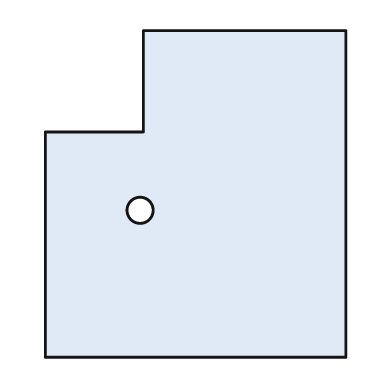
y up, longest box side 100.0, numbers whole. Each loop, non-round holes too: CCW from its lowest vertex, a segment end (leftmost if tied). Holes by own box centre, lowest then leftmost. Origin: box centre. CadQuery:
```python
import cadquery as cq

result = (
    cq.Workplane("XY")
    .moveTo(-46.0, -50.0)
    .lineTo(46.0, -50.0)
    .lineTo(46.0, 50.0)
    .lineTo(-16.0, 50.0)
    .lineTo(-16.0, 19.0)
    .lineTo(-46.0, 19.0)
    .close()
    .moveTo(-17.0, -5.0)
    .circle(4.0)
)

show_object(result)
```